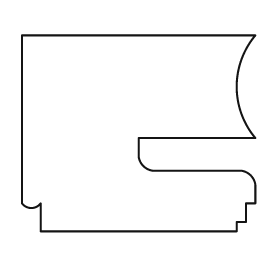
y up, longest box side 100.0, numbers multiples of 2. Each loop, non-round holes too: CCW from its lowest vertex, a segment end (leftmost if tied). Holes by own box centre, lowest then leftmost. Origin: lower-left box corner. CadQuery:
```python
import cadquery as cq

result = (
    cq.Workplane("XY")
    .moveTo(8.0, 0.0)
    .lineTo(92.0, 0.0)
    .lineTo(92.0, 4.0)
    .lineTo(96.0, 4.0)
    .lineTo(96.0, 12.0)
    .lineTo(100.0, 12.0)
    .lineTo(100.0, 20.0)
    .threePointArc((98.0, 24.0), (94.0, 26.0))
    .lineTo(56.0, 26.0)
    .threePointArc((52.0, 28.0), (50.0, 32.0))
    .lineTo(50.0, 40.0)
    .lineTo(100.0, 40.0)
    .threePointArc((92.0, 62.0), (100.0, 84.0))
    .lineTo(0.0, 84.0)
    .lineTo(0.0, 12.0)
    .threePointArc((4.0, 10.0), (8.0, 12.0))
    .close()
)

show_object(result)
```